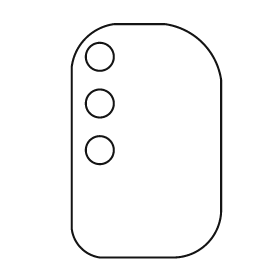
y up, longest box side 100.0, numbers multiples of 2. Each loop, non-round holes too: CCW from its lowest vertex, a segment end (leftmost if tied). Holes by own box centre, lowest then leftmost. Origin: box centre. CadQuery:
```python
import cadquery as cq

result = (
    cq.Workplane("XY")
    .moveTo(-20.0, -50.0)
    .lineTo(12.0, -50.0)
    .threePointArc((26.0, -44.0), (32.0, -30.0))
    .lineTo(32.0, 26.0)
    .threePointArc((24.0, 42.0), (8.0, 50.0))
    .lineTo(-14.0, 50.0)
    .threePointArc((-26.0, 44.0), (-32.0, 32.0))
    .lineTo(-32.0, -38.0)
    .threePointArc((-28.0, -46.0), (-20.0, -50.0))
    .close()
    .moveTo(-20.0, -4.0)
    .circle(6.0)
    .moveTo(-20.0, 16.0)
    .circle(6.0)
    .moveTo(-20.0, 36.0)
    .circle(6.0)
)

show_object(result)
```